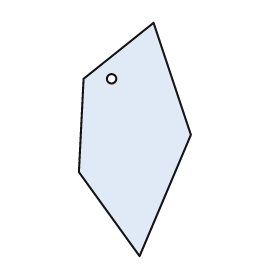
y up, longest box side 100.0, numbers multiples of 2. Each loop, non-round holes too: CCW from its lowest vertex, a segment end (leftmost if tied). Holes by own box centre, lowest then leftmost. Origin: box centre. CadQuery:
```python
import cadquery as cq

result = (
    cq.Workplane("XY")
    .moveTo(2.0, -50.0)
    .lineTo(24.0, 2.0)
    .lineTo(8.0, 50.0)
    .lineTo(-22.0, 26.0)
    .lineTo(-24.0, -14.0)
    .close()
    .moveTo(-10.0, 26.0)
    .circle(2.0)
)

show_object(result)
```